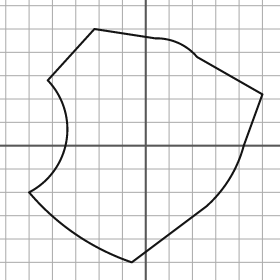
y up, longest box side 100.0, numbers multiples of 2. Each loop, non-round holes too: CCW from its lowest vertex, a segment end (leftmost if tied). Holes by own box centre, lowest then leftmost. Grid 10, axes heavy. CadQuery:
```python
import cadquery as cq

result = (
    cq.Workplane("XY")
    .moveTo(-6.0, -50.0)
    .lineTo(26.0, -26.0)
    .threePointArc((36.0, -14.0), (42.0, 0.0))
    .lineTo(50.0, 22.0)
    .lineTo(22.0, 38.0)
    .threePointArc((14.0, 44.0), (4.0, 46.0))
    .lineTo(-22.0, 50.0)
    .lineTo(-42.0, 28.0)
    .threePointArc((-34.0, 2.0), (-50.0, -20.0))
    .threePointArc((-30.0, -38.0), (-6.0, -50.0))
    .close()
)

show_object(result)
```